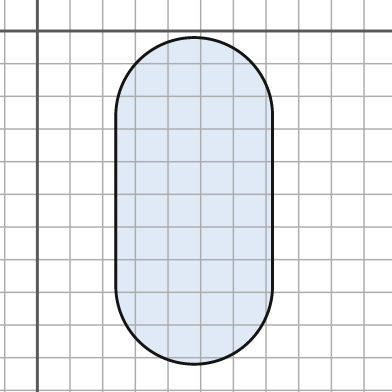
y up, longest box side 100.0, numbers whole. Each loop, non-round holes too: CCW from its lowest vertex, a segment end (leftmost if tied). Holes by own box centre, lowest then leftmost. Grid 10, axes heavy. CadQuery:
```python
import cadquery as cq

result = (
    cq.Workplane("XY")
    .moveTo(24.0, -78.0)
    .threePointArc((48.0, -102.0), (72.0, -78.0))
    .lineTo(72.0, -26.0)
    .threePointArc((48.0, -2.0), (24.0, -26.0))
    .close()
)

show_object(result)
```